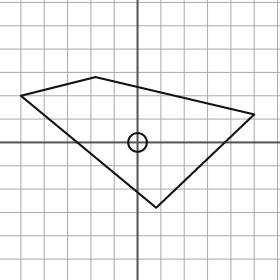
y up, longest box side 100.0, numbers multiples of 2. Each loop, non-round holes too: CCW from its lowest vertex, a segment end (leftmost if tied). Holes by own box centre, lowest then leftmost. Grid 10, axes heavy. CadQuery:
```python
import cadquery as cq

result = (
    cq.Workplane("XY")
    .moveTo(8.0, -28.0)
    .lineTo(50.0, 12.0)
    .lineTo(-18.0, 28.0)
    .lineTo(-50.0, 20.0)
    .close()
    .moveTo(0.0, 0.0)
    .circle(4.0)
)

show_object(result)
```